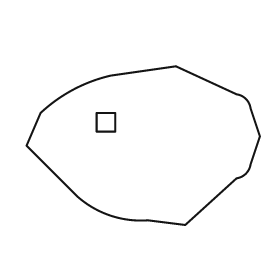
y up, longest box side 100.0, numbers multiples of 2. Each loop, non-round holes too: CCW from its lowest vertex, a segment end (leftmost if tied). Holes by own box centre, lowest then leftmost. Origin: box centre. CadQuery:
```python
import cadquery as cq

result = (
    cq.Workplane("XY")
    .moveTo(18.0, -34.0)
    .lineTo(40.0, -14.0)
    .threePointArc((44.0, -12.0), (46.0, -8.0))
    .lineTo(50.0, 4.0)
    .lineTo(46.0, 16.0)
    .threePointArc((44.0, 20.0), (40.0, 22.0))
    .lineTo(14.0, 34.0)
    .lineTo(-14.0, 30.0)
    .threePointArc((-30.0, 24.0), (-44.0, 14.0))
    .lineTo(-50.0, 0.0)
    .lineTo(-28.0, -22.0)
    .threePointArc((-14.0, -30.0), (2.0, -32.0))
    .close()
    .moveTo(-20.0, 6.0)
    .lineTo(-12.0, 6.0)
    .lineTo(-12.0, 14.0)
    .lineTo(-20.0, 14.0)
    .close()
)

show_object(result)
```